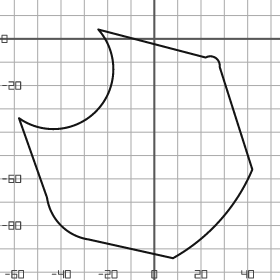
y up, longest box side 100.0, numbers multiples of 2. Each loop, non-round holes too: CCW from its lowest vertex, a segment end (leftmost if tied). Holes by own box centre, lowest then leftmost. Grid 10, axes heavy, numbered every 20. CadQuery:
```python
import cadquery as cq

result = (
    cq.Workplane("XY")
    .moveTo(8.0, -94.0)
    .threePointArc((28.0, -78.0), (42.0, -56.0))
    .lineTo(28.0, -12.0)
    .threePointArc((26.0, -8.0), (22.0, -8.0))
    .lineTo(-24.0, 4.0)
    .threePointArc((-24.0, -30.0), (-58.0, -34.0))
    .lineTo(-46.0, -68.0)
    .threePointArc((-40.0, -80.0), (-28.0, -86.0))
    .close()
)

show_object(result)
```